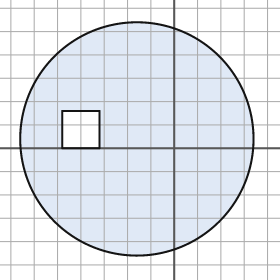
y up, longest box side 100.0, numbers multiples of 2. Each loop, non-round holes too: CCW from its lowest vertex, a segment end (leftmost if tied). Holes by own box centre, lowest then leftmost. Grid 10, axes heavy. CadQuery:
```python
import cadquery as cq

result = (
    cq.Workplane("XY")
    .moveTo(-16.0, 4.0)
    .circle(50.0)
    .moveTo(-48.0, 0.0)
    .lineTo(-32.0, 0.0)
    .lineTo(-32.0, 16.0)
    .lineTo(-48.0, 16.0)
    .close()
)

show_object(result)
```